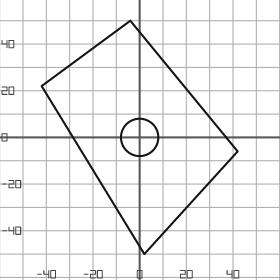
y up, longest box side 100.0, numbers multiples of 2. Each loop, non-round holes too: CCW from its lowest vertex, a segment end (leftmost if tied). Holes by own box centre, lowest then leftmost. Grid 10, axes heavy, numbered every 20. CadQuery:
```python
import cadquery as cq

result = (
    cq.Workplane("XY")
    .moveTo(2.0, -50.0)
    .lineTo(42.0, -6.0)
    .lineTo(-4.0, 50.0)
    .lineTo(-42.0, 22.0)
    .close()
    .moveTo(0.0, 0.0)
    .circle(8.0)
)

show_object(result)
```